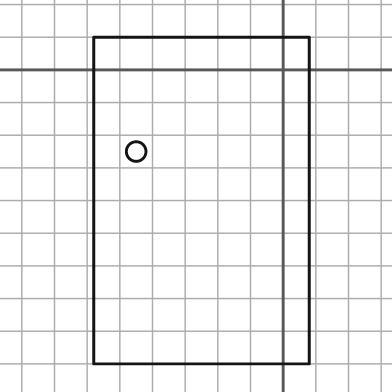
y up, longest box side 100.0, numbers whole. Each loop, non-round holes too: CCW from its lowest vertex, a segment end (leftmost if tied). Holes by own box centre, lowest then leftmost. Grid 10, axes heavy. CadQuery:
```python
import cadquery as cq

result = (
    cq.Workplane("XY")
    .moveTo(-58.0, -90.0)
    .lineTo(8.0, -90.0)
    .lineTo(8.0, 10.0)
    .lineTo(-58.0, 10.0)
    .close()
    .moveTo(-45.0, -25.0)
    .circle(3.0)
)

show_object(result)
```